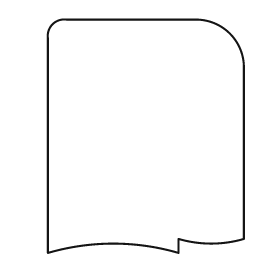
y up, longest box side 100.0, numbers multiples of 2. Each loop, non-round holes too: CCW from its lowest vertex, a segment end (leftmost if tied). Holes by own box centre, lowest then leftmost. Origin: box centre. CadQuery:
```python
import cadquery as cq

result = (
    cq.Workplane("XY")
    .moveTo(-42.0, -50.0)
    .threePointArc((-14.0, -46.0), (14.0, -50.0))
    .lineTo(14.0, -44.0)
    .threePointArc((28.0, -46.0), (42.0, -44.0))
    .lineTo(42.0, 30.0)
    .threePointArc((36.0, 44.0), (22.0, 50.0))
    .lineTo(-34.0, 50.0)
    .threePointArc((-40.0, 48.0), (-42.0, 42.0))
    .close()
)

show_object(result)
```